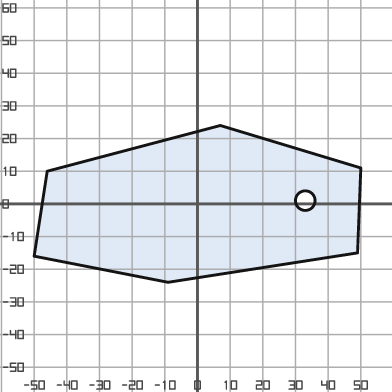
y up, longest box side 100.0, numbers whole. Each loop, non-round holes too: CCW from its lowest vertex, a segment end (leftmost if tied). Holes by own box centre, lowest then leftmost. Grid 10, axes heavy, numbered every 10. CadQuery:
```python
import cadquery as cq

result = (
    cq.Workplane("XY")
    .moveTo(-9.0, -24.0)
    .lineTo(49.0, -15.0)
    .lineTo(50.0, 11.0)
    .lineTo(7.0, 24.0)
    .lineTo(-46.0, 10.0)
    .lineTo(-50.0, -16.0)
    .close()
    .moveTo(33.0, 1.0)
    .circle(3.0)
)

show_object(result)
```